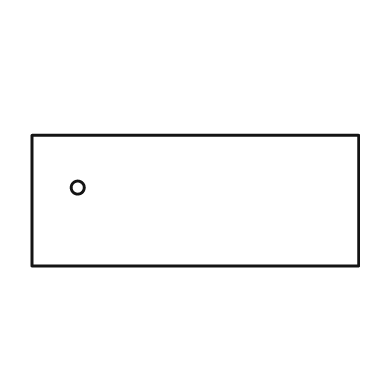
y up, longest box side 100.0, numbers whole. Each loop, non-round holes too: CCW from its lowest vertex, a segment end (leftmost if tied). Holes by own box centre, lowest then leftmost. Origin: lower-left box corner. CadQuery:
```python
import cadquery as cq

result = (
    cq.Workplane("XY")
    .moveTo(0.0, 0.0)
    .lineTo(100.0, 0.0)
    .lineTo(100.0, 40.0)
    .lineTo(0.0, 40.0)
    .close()
    .moveTo(14.0, 24.0)
    .circle(2.0)
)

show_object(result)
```